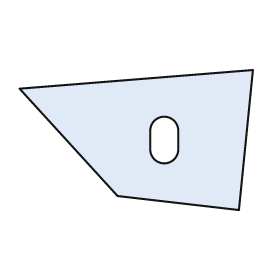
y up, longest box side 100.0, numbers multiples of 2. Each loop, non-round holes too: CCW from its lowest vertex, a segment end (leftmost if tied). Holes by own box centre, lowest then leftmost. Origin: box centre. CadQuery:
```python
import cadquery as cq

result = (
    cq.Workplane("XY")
    .moveTo(44.0, -30.0)
    .lineTo(50.0, 30.0)
    .lineTo(-50.0, 22.0)
    .lineTo(-8.0, -24.0)
    .close()
    .moveTo(6.0, -4.0)
    .threePointArc((12.0, -10.0), (18.0, -4.0))
    .lineTo(18.0, 4.0)
    .threePointArc((12.0, 10.0), (6.0, 4.0))
    .close()
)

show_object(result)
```